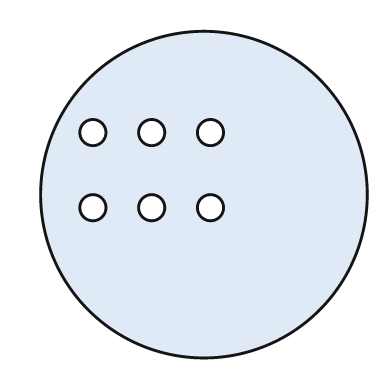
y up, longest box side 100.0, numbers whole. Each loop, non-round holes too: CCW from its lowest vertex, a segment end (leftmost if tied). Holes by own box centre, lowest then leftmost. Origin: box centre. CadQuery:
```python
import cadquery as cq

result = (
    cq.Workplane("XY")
    .moveTo(0.0, 0.0)
    .circle(50.0)
    .moveTo(-34.0, -4.0)
    .circle(4.0)
    .moveTo(-16.0, -4.0)
    .circle(4.0)
    .moveTo(2.0, -4.0)
    .circle(4.0)
    .moveTo(-34.0, 19.0)
    .circle(4.0)
    .moveTo(-16.0, 19.0)
    .circle(4.0)
    .moveTo(2.0, 19.0)
    .circle(4.0)
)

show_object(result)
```